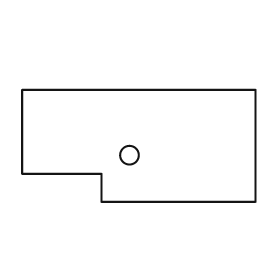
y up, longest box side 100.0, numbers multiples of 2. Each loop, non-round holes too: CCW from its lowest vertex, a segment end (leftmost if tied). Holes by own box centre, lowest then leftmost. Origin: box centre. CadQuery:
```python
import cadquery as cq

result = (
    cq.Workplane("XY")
    .moveTo(-16.0, -24.0)
    .lineTo(50.0, -24.0)
    .lineTo(50.0, 24.0)
    .lineTo(-50.0, 24.0)
    .lineTo(-50.0, -12.0)
    .lineTo(-16.0, -12.0)
    .close()
    .moveTo(-4.0, -4.0)
    .circle(4.0)
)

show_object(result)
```